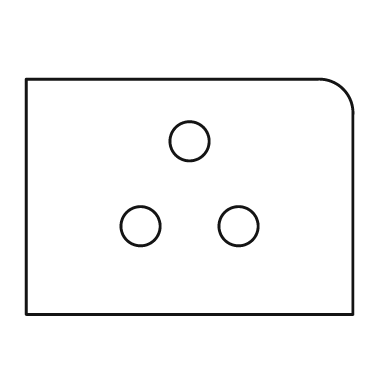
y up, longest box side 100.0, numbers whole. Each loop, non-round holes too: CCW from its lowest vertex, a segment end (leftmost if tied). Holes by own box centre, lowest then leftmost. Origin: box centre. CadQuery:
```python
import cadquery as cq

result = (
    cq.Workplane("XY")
    .moveTo(-50.0, -36.0)
    .lineTo(50.0, -36.0)
    .lineTo(50.0, 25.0)
    .threePointArc((47.0, 33.0), (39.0, 36.0))
    .lineTo(-50.0, 36.0)
    .close()
    .moveTo(-15.0, -9.0)
    .circle(6.0)
    .moveTo(15.0, -9.0)
    .circle(6.0)
    .moveTo(0.0, 17.0)
    .circle(6.0)
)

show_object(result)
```